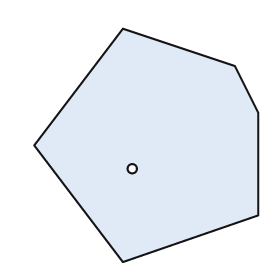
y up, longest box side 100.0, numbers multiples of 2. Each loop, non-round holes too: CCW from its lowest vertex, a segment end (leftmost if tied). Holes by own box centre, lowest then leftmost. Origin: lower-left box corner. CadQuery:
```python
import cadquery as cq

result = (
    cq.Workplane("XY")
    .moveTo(38.0, 0.0)
    .lineTo(96.0, 20.0)
    .lineTo(96.0, 64.0)
    .lineTo(86.0, 84.0)
    .lineTo(38.0, 100.0)
    .lineTo(0.0, 50.0)
    .close()
    .moveTo(42.0, 40.0)
    .circle(2.0)
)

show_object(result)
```